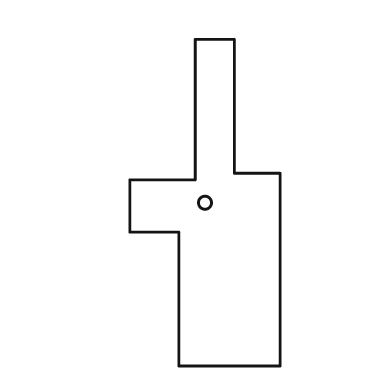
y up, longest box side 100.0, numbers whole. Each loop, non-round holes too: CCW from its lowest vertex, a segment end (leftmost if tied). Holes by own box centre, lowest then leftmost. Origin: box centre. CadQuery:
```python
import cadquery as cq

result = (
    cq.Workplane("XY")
    .moveTo(-8.0, -50.0)
    .lineTo(23.0, -50.0)
    .lineTo(23.0, 9.0)
    .lineTo(9.0, 9.0)
    .lineTo(9.0, 50.0)
    .lineTo(-3.0, 50.0)
    .lineTo(-3.0, 7.0)
    .lineTo(-23.0, 7.0)
    .lineTo(-23.0, -9.0)
    .lineTo(-8.0, -9.0)
    .close()
    .moveTo(0.0, 0.0)
    .circle(2.0)
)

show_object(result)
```